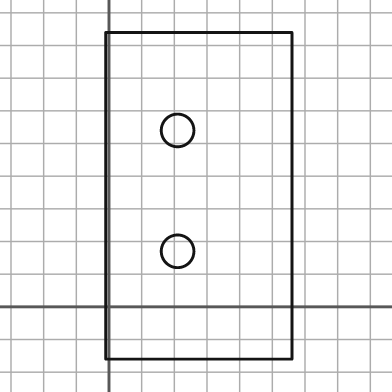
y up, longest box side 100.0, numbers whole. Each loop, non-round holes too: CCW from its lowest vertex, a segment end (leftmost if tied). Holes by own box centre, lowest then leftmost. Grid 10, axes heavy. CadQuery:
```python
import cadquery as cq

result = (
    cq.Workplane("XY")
    .moveTo(-1.0, -16.0)
    .lineTo(56.0, -16.0)
    .lineTo(56.0, 84.0)
    .lineTo(-1.0, 84.0)
    .close()
    .moveTo(21.0, 17.0)
    .circle(5.0)
    .moveTo(21.0, 54.0)
    .circle(5.0)
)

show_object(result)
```